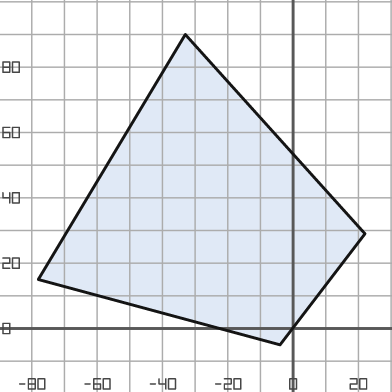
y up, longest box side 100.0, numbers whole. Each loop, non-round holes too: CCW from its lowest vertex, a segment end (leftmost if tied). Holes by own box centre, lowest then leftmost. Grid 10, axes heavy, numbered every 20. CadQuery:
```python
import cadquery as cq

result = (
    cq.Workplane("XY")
    .moveTo(-4.0, -5.0)
    .lineTo(22.0, 29.0)
    .lineTo(-33.0, 90.0)
    .lineTo(-78.0, 15.0)
    .close()
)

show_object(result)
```